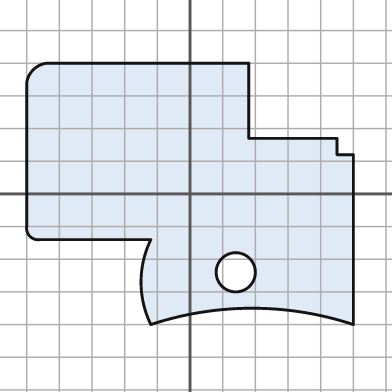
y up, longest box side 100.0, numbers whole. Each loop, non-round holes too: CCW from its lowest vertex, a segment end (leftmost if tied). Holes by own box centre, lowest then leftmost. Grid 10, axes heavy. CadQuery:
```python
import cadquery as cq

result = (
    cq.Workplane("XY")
    .moveTo(-12.0, -40.0)
    .threePointArc((19.0, -35.0), (50.0, -40.0))
    .lineTo(50.0, 12.0)
    .lineTo(45.0, 12.0)
    .lineTo(45.0, 17.0)
    .lineTo(18.0, 17.0)
    .lineTo(18.0, 40.0)
    .lineTo(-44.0, 40.0)
    .threePointArc((-48.0, 38.0), (-50.0, 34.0))
    .lineTo(-50.0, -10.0)
    .threePointArc((-49.0, -13.0), (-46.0, -14.0))
    .lineTo(-12.0, -14.0)
    .threePointArc((-15.0, -27.0), (-12.0, -40.0))
    .close()
    .moveTo(14.0, -24.0)
    .circle(6.0)
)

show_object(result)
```